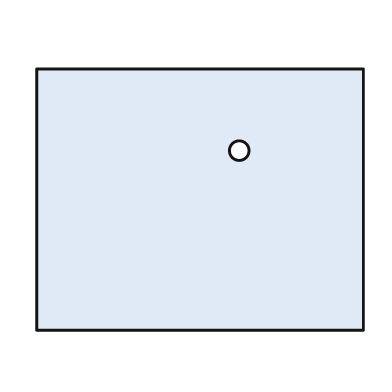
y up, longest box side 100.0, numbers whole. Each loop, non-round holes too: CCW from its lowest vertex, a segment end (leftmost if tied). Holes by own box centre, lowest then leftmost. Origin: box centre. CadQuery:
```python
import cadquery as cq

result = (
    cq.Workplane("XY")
    .moveTo(-50.0, -40.0)
    .lineTo(50.0, -40.0)
    .lineTo(50.0, 40.0)
    .lineTo(-50.0, 40.0)
    .close()
    .moveTo(12.0, 15.0)
    .circle(3.0)
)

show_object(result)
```